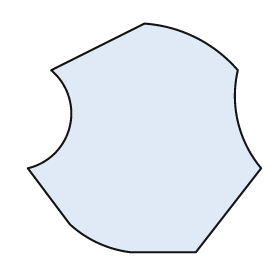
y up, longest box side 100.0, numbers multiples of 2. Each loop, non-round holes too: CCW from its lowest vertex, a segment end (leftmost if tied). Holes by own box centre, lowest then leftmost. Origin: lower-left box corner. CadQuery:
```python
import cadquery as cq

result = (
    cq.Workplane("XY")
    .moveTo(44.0, 0.0)
    .lineTo(72.0, 0.0)
    .lineTo(100.0, 36.0)
    .threePointArc((90.0, 56.0), (90.0, 78.0))
    .threePointArc((72.0, 92.0), (50.0, 98.0))
    .lineTo(10.0, 78.0)
    .threePointArc((18.0, 54.0), (0.0, 36.0))
    .lineTo(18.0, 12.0)
    .threePointArc((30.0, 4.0), (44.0, 0.0))
    .close()
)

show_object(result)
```